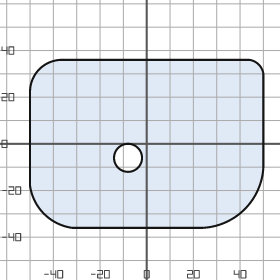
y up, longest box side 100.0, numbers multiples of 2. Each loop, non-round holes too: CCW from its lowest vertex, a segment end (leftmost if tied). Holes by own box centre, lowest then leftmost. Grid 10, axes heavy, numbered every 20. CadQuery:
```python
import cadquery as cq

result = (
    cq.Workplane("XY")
    .moveTo(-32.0, -36.0)
    .lineTo(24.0, -36.0)
    .threePointArc((42.0, -28.0), (50.0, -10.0))
    .lineTo(50.0, 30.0)
    .threePointArc((48.0, 34.0), (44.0, 36.0))
    .lineTo(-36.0, 36.0)
    .threePointArc((-46.0, 32.0), (-50.0, 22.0))
    .lineTo(-50.0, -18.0)
    .threePointArc((-44.0, -30.0), (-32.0, -36.0))
    .close()
    .moveTo(-8.0, -6.0)
    .circle(6.0)
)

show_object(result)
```